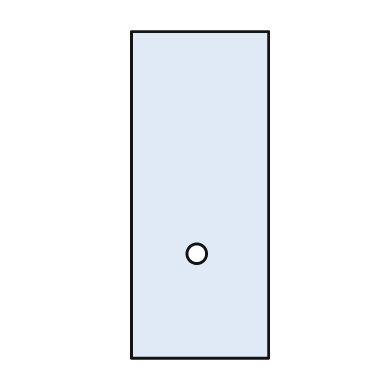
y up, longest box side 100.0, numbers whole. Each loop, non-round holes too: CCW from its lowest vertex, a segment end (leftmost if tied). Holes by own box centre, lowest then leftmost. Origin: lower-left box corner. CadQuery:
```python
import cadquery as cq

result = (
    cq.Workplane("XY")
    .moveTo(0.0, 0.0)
    .lineTo(42.0, 0.0)
    .lineTo(42.0, 100.0)
    .lineTo(0.0, 100.0)
    .close()
    .moveTo(20.0, 32.0)
    .circle(3.0)
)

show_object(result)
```